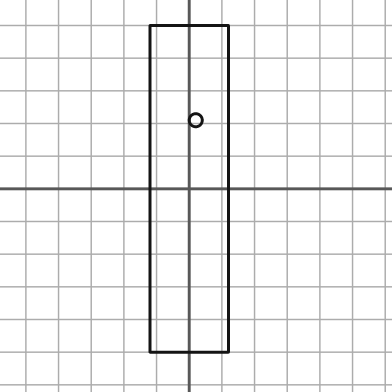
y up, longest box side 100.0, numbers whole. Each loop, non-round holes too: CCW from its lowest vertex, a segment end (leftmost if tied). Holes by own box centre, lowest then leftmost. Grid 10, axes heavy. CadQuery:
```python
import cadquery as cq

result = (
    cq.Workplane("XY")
    .moveTo(-12.0, -50.0)
    .lineTo(12.0, -50.0)
    .lineTo(12.0, 50.0)
    .lineTo(-12.0, 50.0)
    .close()
    .moveTo(2.0, 21.0)
    .circle(2.0)
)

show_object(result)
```